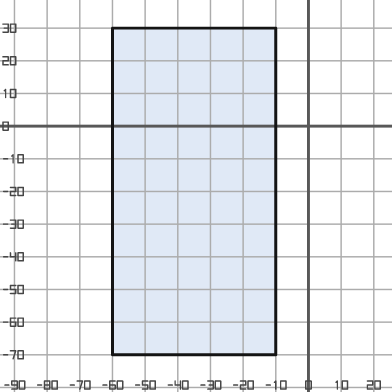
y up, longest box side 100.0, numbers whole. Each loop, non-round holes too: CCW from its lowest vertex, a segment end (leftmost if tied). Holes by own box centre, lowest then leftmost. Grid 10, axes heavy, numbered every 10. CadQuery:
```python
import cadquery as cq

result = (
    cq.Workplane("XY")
    .moveTo(-60.0, -70.0)
    .lineTo(-10.0, -70.0)
    .lineTo(-10.0, 30.0)
    .lineTo(-60.0, 30.0)
    .close()
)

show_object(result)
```